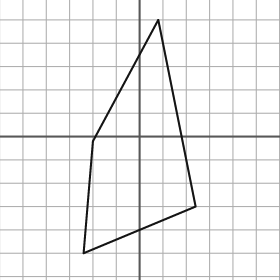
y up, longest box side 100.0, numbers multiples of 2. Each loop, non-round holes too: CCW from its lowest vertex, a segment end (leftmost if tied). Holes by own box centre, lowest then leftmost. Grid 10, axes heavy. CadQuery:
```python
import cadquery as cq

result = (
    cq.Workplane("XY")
    .moveTo(-24.0, -50.0)
    .lineTo(24.0, -30.0)
    .lineTo(8.0, 50.0)
    .lineTo(-20.0, -2.0)
    .close()
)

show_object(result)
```